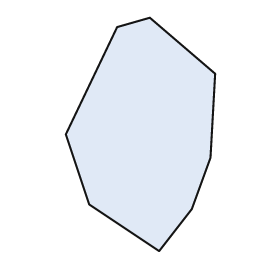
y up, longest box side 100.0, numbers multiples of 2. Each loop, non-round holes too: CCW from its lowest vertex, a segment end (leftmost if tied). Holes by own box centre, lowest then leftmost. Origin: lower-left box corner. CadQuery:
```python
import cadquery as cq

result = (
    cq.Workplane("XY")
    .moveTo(40.0, 0.0)
    .lineTo(54.0, 18.0)
    .lineTo(62.0, 40.0)
    .lineTo(64.0, 76.0)
    .lineTo(36.0, 100.0)
    .lineTo(22.0, 96.0)
    .lineTo(0.0, 50.0)
    .lineTo(10.0, 20.0)
    .close()
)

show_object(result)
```